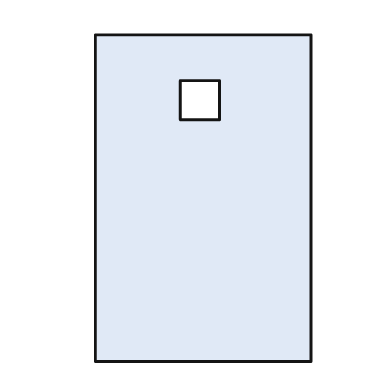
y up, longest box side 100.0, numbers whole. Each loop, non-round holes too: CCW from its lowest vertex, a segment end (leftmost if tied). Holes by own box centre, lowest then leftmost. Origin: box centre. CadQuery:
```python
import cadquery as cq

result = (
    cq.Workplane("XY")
    .moveTo(-33.0, -50.0)
    .lineTo(33.0, -50.0)
    .lineTo(33.0, 50.0)
    .lineTo(-33.0, 50.0)
    .close()
    .moveTo(-7.0, 24.0)
    .lineTo(5.0, 24.0)
    .lineTo(5.0, 36.0)
    .lineTo(-7.0, 36.0)
    .close()
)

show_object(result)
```